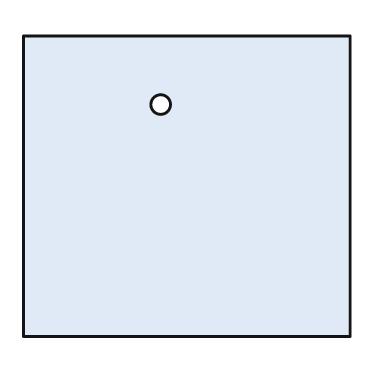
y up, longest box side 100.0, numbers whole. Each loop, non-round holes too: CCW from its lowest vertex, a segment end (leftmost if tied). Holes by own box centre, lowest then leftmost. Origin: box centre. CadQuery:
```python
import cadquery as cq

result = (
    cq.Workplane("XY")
    .moveTo(-50.0, -46.0)
    .lineTo(50.0, -46.0)
    .lineTo(50.0, 46.0)
    .lineTo(-50.0, 46.0)
    .close()
    .moveTo(-8.0, 25.0)
    .circle(3.0)
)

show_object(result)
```